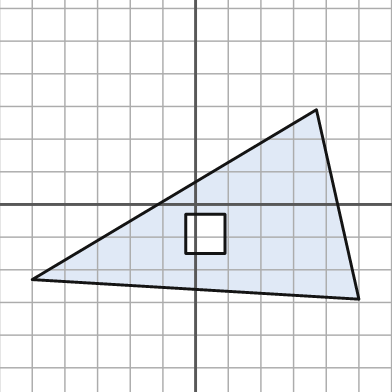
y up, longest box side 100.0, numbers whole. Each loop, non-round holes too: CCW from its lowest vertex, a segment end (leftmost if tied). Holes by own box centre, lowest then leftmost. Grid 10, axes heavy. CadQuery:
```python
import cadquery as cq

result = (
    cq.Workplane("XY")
    .moveTo(50.0, -29.0)
    .lineTo(37.0, 29.0)
    .lineTo(-50.0, -23.0)
    .close()
    .moveTo(-3.0, -15.0)
    .lineTo(9.0, -15.0)
    .lineTo(9.0, -3.0)
    .lineTo(-3.0, -3.0)
    .close()
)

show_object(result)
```